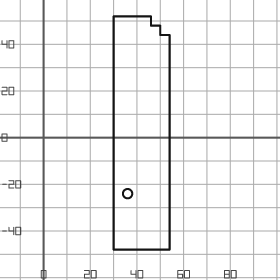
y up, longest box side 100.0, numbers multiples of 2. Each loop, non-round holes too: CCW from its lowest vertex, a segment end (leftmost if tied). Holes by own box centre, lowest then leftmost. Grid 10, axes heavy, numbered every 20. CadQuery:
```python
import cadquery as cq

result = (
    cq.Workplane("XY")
    .moveTo(30.0, -48.0)
    .lineTo(54.0, -48.0)
    .lineTo(54.0, 44.0)
    .lineTo(50.0, 44.0)
    .lineTo(50.0, 48.0)
    .lineTo(46.0, 48.0)
    .lineTo(46.0, 52.0)
    .lineTo(30.0, 52.0)
    .close()
    .moveTo(36.0, -24.0)
    .circle(2.0)
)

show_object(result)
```